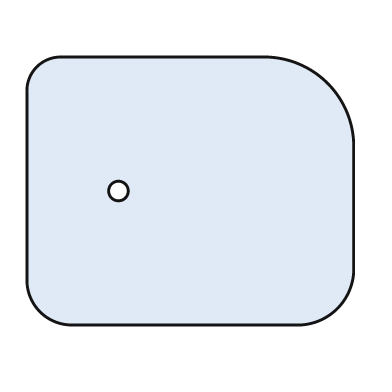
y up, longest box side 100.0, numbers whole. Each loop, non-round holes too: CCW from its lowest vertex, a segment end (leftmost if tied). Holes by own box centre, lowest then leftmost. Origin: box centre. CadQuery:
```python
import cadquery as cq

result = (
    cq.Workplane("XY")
    .moveTo(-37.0, -41.0)
    .lineTo(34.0, -41.0)
    .threePointArc((45.0, -36.0), (50.0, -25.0))
    .lineTo(50.0, 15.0)
    .threePointArc((42.0, 33.0), (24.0, 41.0))
    .lineTo(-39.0, 41.0)
    .threePointArc((-47.0, 38.0), (-50.0, 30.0))
    .lineTo(-50.0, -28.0)
    .threePointArc((-46.0, -37.0), (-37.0, -41.0))
    .close()
    .moveTo(-22.0, 0.0)
    .circle(3.0)
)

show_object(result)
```